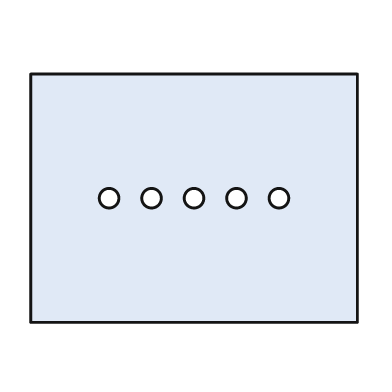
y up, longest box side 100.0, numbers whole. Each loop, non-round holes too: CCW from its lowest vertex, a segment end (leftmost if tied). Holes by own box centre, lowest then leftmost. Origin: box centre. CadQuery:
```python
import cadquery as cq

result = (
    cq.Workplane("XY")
    .moveTo(-50.0, -38.0)
    .lineTo(50.0, -38.0)
    .lineTo(50.0, 38.0)
    .lineTo(-50.0, 38.0)
    .close()
    .moveTo(-26.0, 0.0)
    .circle(3.0)
    .moveTo(-13.0, 0.0)
    .circle(3.0)
    .moveTo(0.0, 0.0)
    .circle(3.0)
    .moveTo(13.0, 0.0)
    .circle(3.0)
    .moveTo(26.0, 0.0)
    .circle(3.0)
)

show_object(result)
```